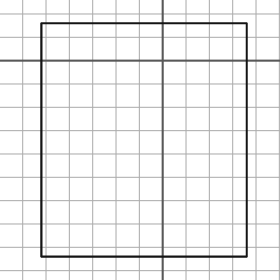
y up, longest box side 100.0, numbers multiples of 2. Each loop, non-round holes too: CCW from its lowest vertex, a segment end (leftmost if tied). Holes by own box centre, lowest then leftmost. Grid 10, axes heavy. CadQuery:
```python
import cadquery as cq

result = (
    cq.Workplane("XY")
    .moveTo(-52.0, -84.0)
    .lineTo(36.0, -84.0)
    .lineTo(36.0, 16.0)
    .lineTo(-52.0, 16.0)
    .close()
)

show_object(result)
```